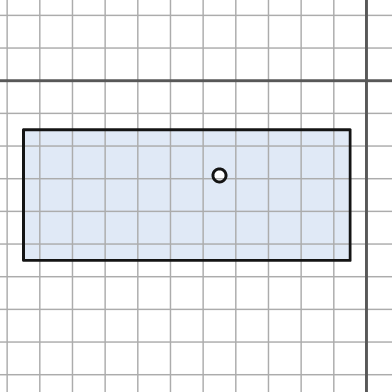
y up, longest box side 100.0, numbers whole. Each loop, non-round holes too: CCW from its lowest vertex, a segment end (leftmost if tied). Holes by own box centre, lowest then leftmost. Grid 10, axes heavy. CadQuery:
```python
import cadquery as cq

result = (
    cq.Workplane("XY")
    .moveTo(-105.0, -55.0)
    .lineTo(-5.0, -55.0)
    .lineTo(-5.0, -15.0)
    .lineTo(-105.0, -15.0)
    .close()
    .moveTo(-45.0, -29.0)
    .circle(2.0)
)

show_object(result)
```